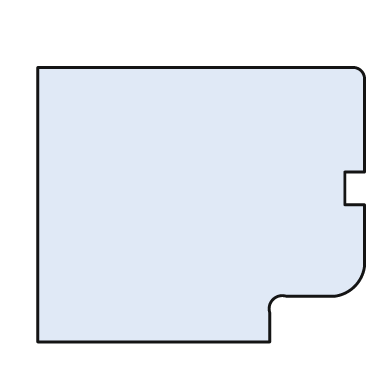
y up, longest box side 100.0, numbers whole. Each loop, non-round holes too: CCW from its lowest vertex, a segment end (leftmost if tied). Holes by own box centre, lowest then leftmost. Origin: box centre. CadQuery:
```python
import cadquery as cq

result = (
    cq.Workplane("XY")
    .moveTo(-50.0, -42.0)
    .lineTo(21.0, -42.0)
    .lineTo(21.0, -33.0)
    .threePointArc((22.0, -29.0), (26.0, -28.0))
    .lineTo(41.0, -28.0)
    .threePointArc((47.0, -25.0), (50.0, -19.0))
    .lineTo(50.0, 0.0)
    .lineTo(44.0, 0.0)
    .lineTo(44.0, 10.0)
    .lineTo(50.0, 10.0)
    .lineTo(50.0, 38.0)
    .threePointArc((49.0, 41.0), (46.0, 42.0))
    .lineTo(-50.0, 42.0)
    .close()
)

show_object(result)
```